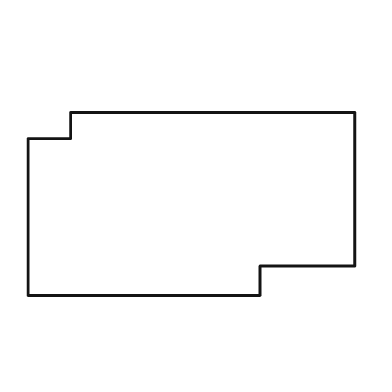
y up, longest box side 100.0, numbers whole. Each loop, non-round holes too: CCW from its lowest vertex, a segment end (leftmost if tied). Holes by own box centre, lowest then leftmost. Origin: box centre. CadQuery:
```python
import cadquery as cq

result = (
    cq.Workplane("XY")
    .moveTo(-50.0, -28.0)
    .lineTo(21.0, -28.0)
    .lineTo(21.0, -19.0)
    .lineTo(50.0, -19.0)
    .lineTo(50.0, 28.0)
    .lineTo(-37.0, 28.0)
    .lineTo(-37.0, 20.0)
    .lineTo(-50.0, 20.0)
    .close()
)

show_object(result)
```